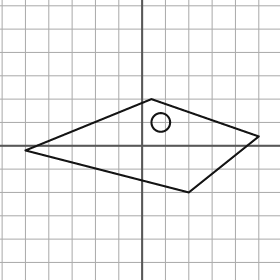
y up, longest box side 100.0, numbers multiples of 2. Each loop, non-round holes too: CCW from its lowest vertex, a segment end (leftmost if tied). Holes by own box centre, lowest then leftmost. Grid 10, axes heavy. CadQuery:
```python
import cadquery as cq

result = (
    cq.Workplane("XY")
    .moveTo(20.0, -20.0)
    .lineTo(50.0, 4.0)
    .lineTo(4.0, 20.0)
    .lineTo(-50.0, -2.0)
    .close()
    .moveTo(8.0, 10.0)
    .circle(4.0)
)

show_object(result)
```